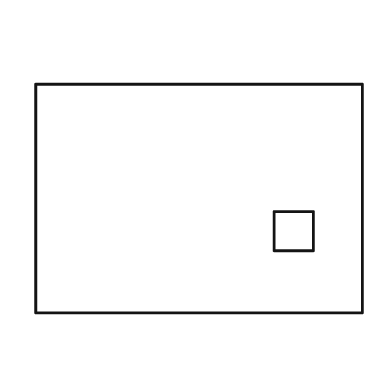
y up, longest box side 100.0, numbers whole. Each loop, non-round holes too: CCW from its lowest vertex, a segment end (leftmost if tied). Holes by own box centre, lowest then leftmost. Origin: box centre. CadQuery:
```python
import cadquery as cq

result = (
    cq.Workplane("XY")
    .moveTo(-50.0, -35.0)
    .lineTo(50.0, -35.0)
    .lineTo(50.0, 35.0)
    .lineTo(-50.0, 35.0)
    .close()
    .moveTo(23.0, -16.0)
    .lineTo(35.0, -16.0)
    .lineTo(35.0, -4.0)
    .lineTo(23.0, -4.0)
    .close()
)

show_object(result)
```